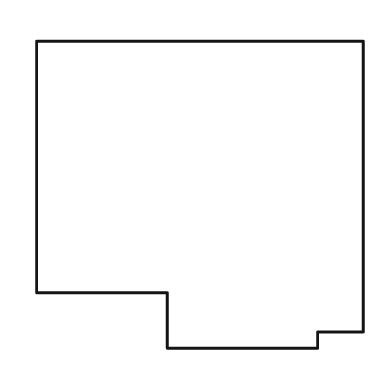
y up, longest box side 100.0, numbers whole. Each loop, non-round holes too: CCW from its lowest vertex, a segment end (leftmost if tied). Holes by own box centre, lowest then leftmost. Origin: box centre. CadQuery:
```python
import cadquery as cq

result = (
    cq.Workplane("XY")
    .moveTo(-10.0, -47.0)
    .lineTo(36.0, -47.0)
    .lineTo(36.0, -42.0)
    .lineTo(50.0, -42.0)
    .lineTo(50.0, 47.0)
    .lineTo(-50.0, 47.0)
    .lineTo(-50.0, -30.0)
    .lineTo(-10.0, -30.0)
    .close()
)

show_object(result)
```